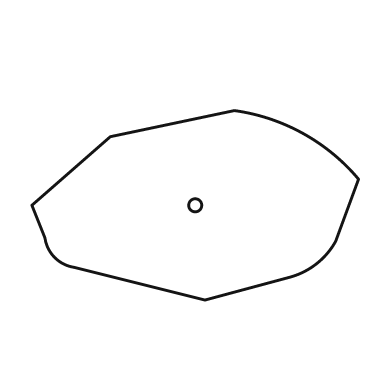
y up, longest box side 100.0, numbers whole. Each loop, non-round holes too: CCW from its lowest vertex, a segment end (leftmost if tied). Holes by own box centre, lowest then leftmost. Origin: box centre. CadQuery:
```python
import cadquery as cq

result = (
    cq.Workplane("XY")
    .moveTo(3.0, -29.0)
    .lineTo(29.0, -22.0)
    .threePointArc((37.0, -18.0), (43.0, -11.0))
    .lineTo(50.0, 8.0)
    .threePointArc((33.0, 22.0), (12.0, 29.0))
    .lineTo(-26.0, 21.0)
    .lineTo(-50.0, 0.0)
    .lineTo(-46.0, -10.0)
    .threePointArc((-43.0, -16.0), (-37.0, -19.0))
    .close()
    .moveTo(0.0, 0.0)
    .circle(2.0)
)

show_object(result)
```